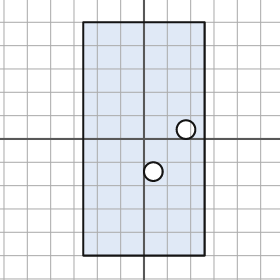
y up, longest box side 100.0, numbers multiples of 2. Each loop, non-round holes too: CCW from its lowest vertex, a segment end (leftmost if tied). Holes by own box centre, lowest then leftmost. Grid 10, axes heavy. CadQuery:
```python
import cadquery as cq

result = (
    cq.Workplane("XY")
    .moveTo(-26.0, -50.0)
    .lineTo(26.0, -50.0)
    .lineTo(26.0, 50.0)
    .lineTo(-26.0, 50.0)
    .close()
    .moveTo(4.0, -14.0)
    .circle(4.0)
    .moveTo(18.0, 4.0)
    .circle(4.0)
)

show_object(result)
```